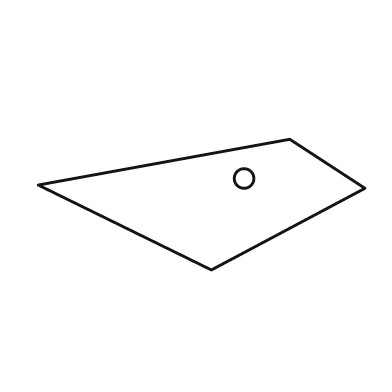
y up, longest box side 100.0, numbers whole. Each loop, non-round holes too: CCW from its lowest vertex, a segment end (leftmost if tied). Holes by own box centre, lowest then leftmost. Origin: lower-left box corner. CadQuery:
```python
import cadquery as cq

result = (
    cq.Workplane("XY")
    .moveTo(53.0, 0.0)
    .lineTo(100.0, 25.0)
    .lineTo(77.0, 40.0)
    .lineTo(0.0, 26.0)
    .close()
    .moveTo(63.0, 28.0)
    .circle(3.0)
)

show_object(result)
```